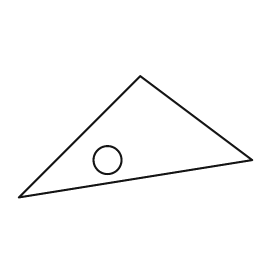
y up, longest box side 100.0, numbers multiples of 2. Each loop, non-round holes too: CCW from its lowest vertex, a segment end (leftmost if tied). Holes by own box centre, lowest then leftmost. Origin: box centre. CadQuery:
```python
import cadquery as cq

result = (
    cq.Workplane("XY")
    .moveTo(-50.0, -26.0)
    .lineTo(50.0, -10.0)
    .lineTo(2.0, 26.0)
    .close()
    .moveTo(-12.0, -10.0)
    .circle(6.0)
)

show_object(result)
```